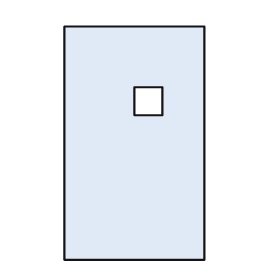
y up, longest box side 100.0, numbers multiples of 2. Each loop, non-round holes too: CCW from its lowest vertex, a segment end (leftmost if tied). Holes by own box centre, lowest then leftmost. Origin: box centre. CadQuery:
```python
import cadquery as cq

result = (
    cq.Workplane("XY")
    .moveTo(-30.0, -50.0)
    .lineTo(30.0, -50.0)
    .lineTo(30.0, 50.0)
    .lineTo(-30.0, 50.0)
    .close()
    .moveTo(0.0, 12.0)
    .lineTo(12.0, 12.0)
    .lineTo(12.0, 24.0)
    .lineTo(0.0, 24.0)
    .close()
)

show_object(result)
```